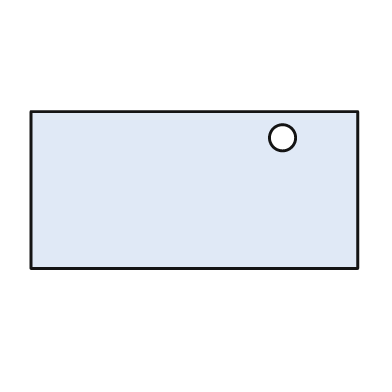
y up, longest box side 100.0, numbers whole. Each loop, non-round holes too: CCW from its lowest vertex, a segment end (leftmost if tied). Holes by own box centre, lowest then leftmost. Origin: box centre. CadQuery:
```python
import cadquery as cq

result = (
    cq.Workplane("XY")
    .moveTo(-50.0, -24.0)
    .lineTo(50.0, -24.0)
    .lineTo(50.0, 24.0)
    .lineTo(-50.0, 24.0)
    .close()
    .moveTo(27.0, 16.0)
    .circle(4.0)
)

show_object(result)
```